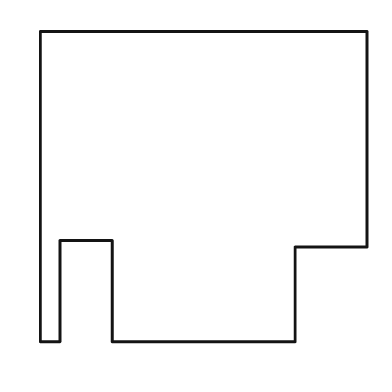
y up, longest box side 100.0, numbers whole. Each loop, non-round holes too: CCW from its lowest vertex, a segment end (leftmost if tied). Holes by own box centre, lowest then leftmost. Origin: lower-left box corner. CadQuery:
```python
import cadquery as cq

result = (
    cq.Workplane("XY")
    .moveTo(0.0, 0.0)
    .lineTo(6.0, 0.0)
    .lineTo(6.0, 31.0)
    .lineTo(22.0, 31.0)
    .lineTo(22.0, 0.0)
    .lineTo(78.0, 0.0)
    .lineTo(78.0, 29.0)
    .lineTo(100.0, 29.0)
    .lineTo(100.0, 95.0)
    .lineTo(0.0, 95.0)
    .close()
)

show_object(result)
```